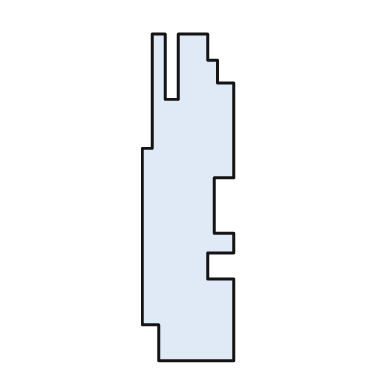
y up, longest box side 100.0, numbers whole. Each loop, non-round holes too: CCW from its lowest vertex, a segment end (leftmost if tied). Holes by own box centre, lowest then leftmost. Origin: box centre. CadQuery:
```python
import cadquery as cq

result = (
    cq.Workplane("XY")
    .moveTo(-9.0, -50.0)
    .lineTo(14.0, -50.0)
    .lineTo(14.0, -25.0)
    .lineTo(6.0, -25.0)
    .lineTo(6.0, -17.0)
    .lineTo(14.0, -17.0)
    .lineTo(14.0, -11.0)
    .lineTo(8.0, -11.0)
    .lineTo(8.0, 6.0)
    .lineTo(14.0, 6.0)
    .lineTo(14.0, 35.0)
    .lineTo(9.0, 35.0)
    .lineTo(9.0, 42.0)
    .lineTo(6.0, 42.0)
    .lineTo(6.0, 50.0)
    .lineTo(-3.0, 50.0)
    .lineTo(-3.0, 30.0)
    .lineTo(-7.0, 30.0)
    .lineTo(-7.0, 50.0)
    .lineTo(-11.0, 50.0)
    .lineTo(-11.0, 15.0)
    .lineTo(-14.0, 15.0)
    .lineTo(-14.0, -39.0)
    .lineTo(-9.0, -39.0)
    .close()
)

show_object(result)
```